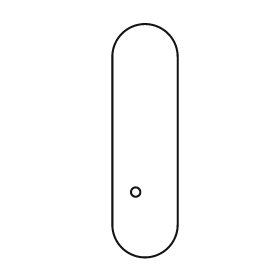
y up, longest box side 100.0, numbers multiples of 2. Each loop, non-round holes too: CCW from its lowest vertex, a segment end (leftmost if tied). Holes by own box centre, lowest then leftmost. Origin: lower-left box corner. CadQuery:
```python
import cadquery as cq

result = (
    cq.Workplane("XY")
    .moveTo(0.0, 14.0)
    .threePointArc((14.0, 0.0), (28.0, 14.0))
    .lineTo(28.0, 86.0)
    .threePointArc((14.0, 100.0), (0.0, 86.0))
    .close()
    .moveTo(10.0, 28.0)
    .circle(2.0)
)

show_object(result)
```